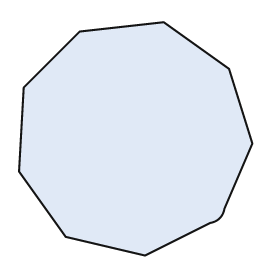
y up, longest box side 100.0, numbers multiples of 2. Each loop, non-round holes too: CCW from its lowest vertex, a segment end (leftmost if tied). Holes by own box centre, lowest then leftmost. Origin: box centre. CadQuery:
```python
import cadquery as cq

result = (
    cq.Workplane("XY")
    .moveTo(4.0, -50.0)
    .lineTo(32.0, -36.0)
    .threePointArc((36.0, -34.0), (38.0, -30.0))
    .lineTo(50.0, -2.0)
    .lineTo(40.0, 30.0)
    .lineTo(12.0, 50.0)
    .lineTo(-24.0, 46.0)
    .lineTo(-48.0, 22.0)
    .lineTo(-50.0, -14.0)
    .lineTo(-30.0, -42.0)
    .close()
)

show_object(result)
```